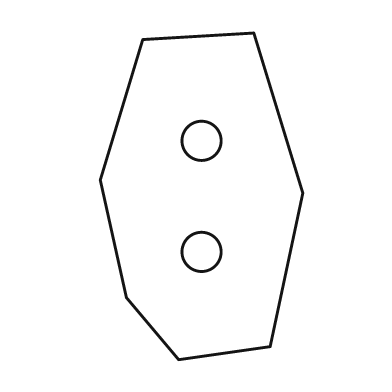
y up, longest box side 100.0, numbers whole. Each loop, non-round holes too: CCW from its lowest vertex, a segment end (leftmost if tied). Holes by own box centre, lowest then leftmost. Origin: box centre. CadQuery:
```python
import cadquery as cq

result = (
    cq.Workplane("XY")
    .moveTo(-7.0, -50.0)
    .lineTo(21.0, -46.0)
    .lineTo(31.0, 1.0)
    .lineTo(16.0, 50.0)
    .lineTo(-18.0, 48.0)
    .lineTo(-31.0, 5.0)
    .lineTo(-23.0, -31.0)
    .close()
    .moveTo(0.0, -17.0)
    .circle(6.0)
    .moveTo(0.0, 17.0)
    .circle(6.0)
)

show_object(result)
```